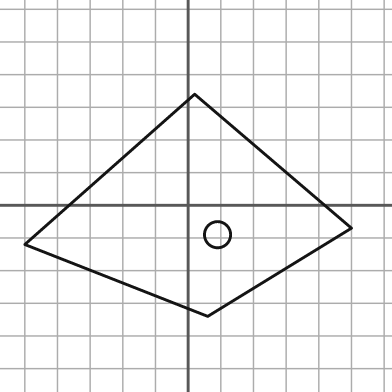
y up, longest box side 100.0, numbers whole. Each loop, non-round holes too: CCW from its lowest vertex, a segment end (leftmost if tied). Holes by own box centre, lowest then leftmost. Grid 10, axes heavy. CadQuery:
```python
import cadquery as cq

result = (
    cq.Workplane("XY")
    .moveTo(6.0, -34.0)
    .lineTo(50.0, -7.0)
    .lineTo(2.0, 34.0)
    .lineTo(-50.0, -12.0)
    .close()
    .moveTo(9.0, -9.0)
    .circle(4.0)
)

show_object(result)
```